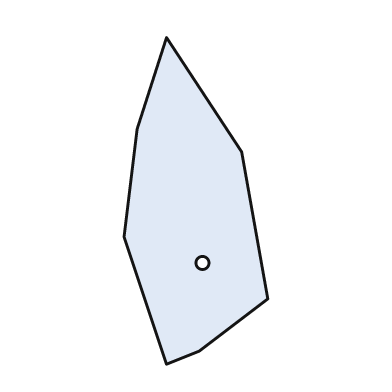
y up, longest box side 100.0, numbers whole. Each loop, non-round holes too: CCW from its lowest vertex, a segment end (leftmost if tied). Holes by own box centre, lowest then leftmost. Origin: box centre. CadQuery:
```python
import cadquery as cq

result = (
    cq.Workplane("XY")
    .moveTo(-9.0, -50.0)
    .lineTo(1.0, -46.0)
    .lineTo(22.0, -30.0)
    .lineTo(14.0, 15.0)
    .lineTo(-9.0, 50.0)
    .lineTo(-18.0, 22.0)
    .lineTo(-22.0, -11.0)
    .close()
    .moveTo(2.0, -19.0)
    .circle(2.0)
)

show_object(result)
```